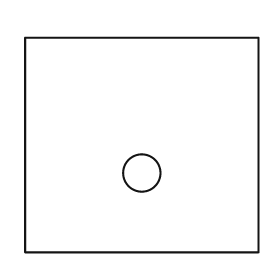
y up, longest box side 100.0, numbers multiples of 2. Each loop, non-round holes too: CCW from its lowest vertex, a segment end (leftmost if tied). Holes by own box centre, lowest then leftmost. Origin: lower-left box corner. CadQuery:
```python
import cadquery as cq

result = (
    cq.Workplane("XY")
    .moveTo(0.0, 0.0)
    .lineTo(100.0, 0.0)
    .lineTo(100.0, 92.0)
    .lineTo(0.0, 92.0)
    .close()
    .moveTo(50.0, 34.0)
    .circle(8.0)
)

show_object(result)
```